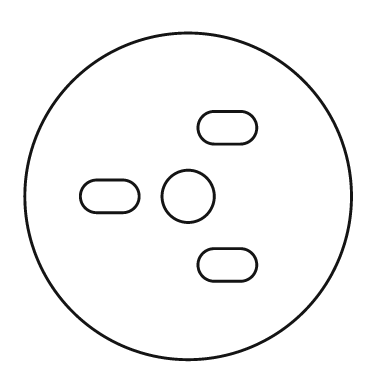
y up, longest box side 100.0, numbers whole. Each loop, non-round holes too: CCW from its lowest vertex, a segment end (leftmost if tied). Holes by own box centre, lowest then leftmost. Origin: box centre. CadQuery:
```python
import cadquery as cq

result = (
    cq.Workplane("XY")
    .moveTo(0.0, 0.0)
    .circle(50.0)
    .moveTo(8.0, -26.0)
    .lineTo(16.0, -26.0)
    .threePointArc((21.0, -21.0), (16.0, -16.0))
    .lineTo(8.0, -16.0)
    .threePointArc((3.0, -21.0), (8.0, -26.0))
    .close()
    .moveTo(-28.0, -5.0)
    .lineTo(-20.0, -5.0)
    .threePointArc((-15.0, 0.0), (-20.0, 5.0))
    .lineTo(-28.0, 5.0)
    .threePointArc((-33.0, 0.0), (-28.0, -5.0))
    .close()
    .moveTo(0.0, 0.0)
    .circle(8.0)
    .moveTo(8.0, 16.0)
    .lineTo(16.0, 16.0)
    .threePointArc((21.0, 21.0), (16.0, 26.0))
    .lineTo(8.0, 26.0)
    .threePointArc((3.0, 21.0), (8.0, 16.0))
    .close()
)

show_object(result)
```